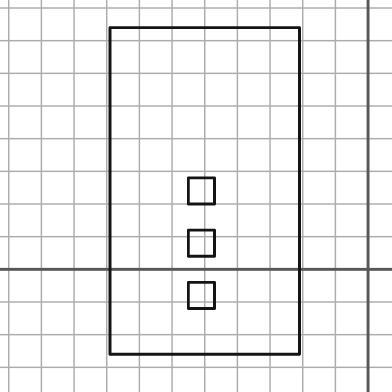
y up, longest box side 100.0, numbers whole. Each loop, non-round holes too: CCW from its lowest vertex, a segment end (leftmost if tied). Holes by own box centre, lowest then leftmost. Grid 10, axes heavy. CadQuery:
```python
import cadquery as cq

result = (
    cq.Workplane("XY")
    .moveTo(-79.0, -26.0)
    .lineTo(-21.0, -26.0)
    .lineTo(-21.0, 74.0)
    .lineTo(-79.0, 74.0)
    .close()
    .moveTo(-55.0, -12.0)
    .lineTo(-47.0, -12.0)
    .lineTo(-47.0, -4.0)
    .lineTo(-55.0, -4.0)
    .close()
    .moveTo(-55.0, 4.0)
    .lineTo(-47.0, 4.0)
    .lineTo(-47.0, 12.0)
    .lineTo(-55.0, 12.0)
    .close()
    .moveTo(-55.0, 20.0)
    .lineTo(-47.0, 20.0)
    .lineTo(-47.0, 28.0)
    .lineTo(-55.0, 28.0)
    .close()
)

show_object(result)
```